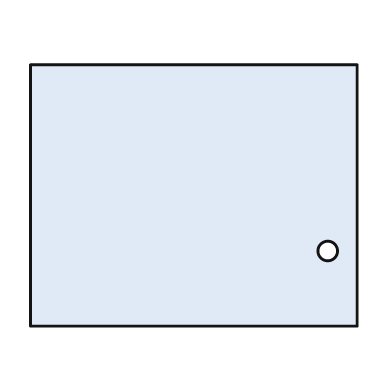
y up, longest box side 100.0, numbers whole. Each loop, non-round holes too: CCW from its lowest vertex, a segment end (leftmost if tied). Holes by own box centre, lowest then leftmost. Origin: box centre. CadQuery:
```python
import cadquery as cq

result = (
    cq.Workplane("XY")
    .moveTo(-50.0, -40.0)
    .lineTo(50.0, -40.0)
    .lineTo(50.0, 40.0)
    .lineTo(-50.0, 40.0)
    .close()
    .moveTo(41.0, -17.0)
    .circle(3.0)
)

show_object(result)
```